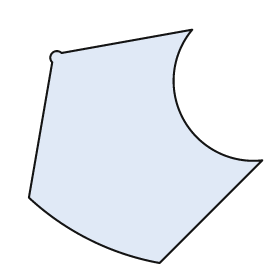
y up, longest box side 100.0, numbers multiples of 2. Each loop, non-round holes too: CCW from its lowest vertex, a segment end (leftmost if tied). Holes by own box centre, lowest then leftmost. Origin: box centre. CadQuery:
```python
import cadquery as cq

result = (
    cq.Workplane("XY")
    .moveTo(6.0, -50.0)
    .lineTo(50.0, -6.0)
    .threePointArc((16.0, 12.0), (20.0, 50.0))
    .lineTo(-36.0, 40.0)
    .threePointArc((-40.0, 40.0), (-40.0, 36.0))
    .lineTo(-50.0, -22.0)
    .threePointArc((-24.0, -40.0), (6.0, -50.0))
    .close()
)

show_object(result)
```